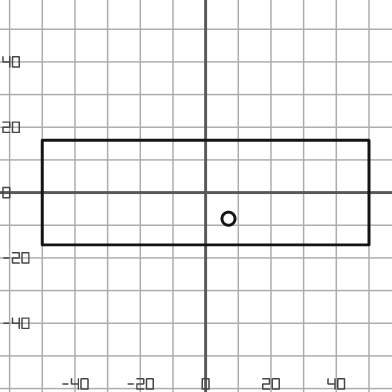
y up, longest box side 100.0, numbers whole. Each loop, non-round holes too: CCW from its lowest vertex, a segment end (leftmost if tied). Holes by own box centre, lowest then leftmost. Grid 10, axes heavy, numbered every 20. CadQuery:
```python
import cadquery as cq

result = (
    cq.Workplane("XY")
    .moveTo(-50.0, -16.0)
    .lineTo(50.0, -16.0)
    .lineTo(50.0, 16.0)
    .lineTo(-50.0, 16.0)
    .close()
    .moveTo(7.0, -8.0)
    .circle(2.0)
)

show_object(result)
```